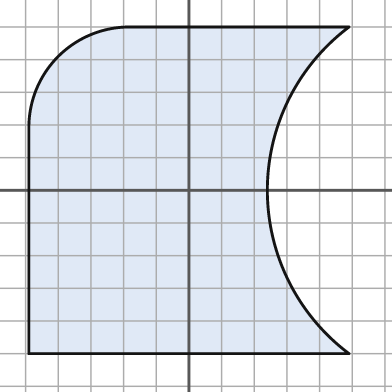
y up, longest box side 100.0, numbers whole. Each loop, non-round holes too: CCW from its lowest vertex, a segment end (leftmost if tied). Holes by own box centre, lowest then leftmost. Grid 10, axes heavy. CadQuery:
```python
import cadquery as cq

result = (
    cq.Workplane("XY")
    .moveTo(-49.0, -50.0)
    .lineTo(49.0, -50.0)
    .threePointArc((24.0, 0.0), (49.0, 50.0))
    .lineTo(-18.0, 50.0)
    .threePointArc((-40.0, 41.0), (-49.0, 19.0))
    .close()
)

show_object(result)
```